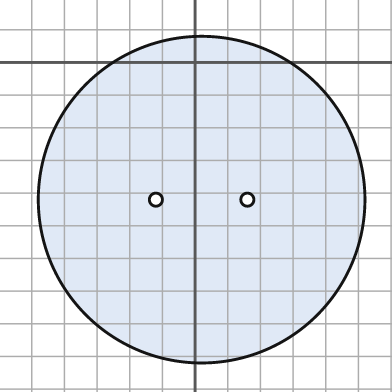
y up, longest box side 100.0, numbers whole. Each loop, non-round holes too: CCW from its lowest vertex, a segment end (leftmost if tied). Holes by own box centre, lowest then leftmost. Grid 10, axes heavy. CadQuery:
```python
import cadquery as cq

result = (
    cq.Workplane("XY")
    .moveTo(2.0, -42.0)
    .circle(50.0)
    .moveTo(-12.0, -42.0)
    .circle(2.0)
    .moveTo(16.0, -42.0)
    .circle(2.0)
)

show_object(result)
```